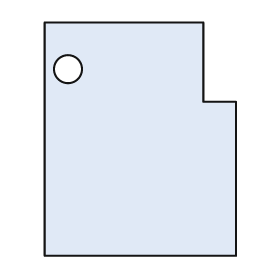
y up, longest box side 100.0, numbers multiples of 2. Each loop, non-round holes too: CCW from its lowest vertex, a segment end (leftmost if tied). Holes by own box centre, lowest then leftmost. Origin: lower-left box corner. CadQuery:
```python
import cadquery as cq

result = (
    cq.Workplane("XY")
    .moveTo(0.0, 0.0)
    .lineTo(82.0, 0.0)
    .lineTo(82.0, 66.0)
    .lineTo(68.0, 66.0)
    .lineTo(68.0, 100.0)
    .lineTo(0.0, 100.0)
    .close()
    .moveTo(10.0, 80.0)
    .circle(6.0)
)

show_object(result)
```